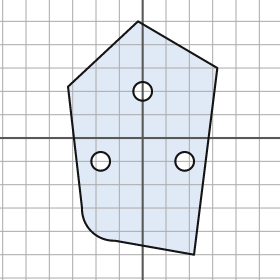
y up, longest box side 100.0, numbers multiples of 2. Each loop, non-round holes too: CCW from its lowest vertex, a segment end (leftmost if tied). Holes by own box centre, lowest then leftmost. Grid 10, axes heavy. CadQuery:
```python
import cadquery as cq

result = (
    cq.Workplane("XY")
    .moveTo(22.0, -50.0)
    .lineTo(32.0, 30.0)
    .lineTo(-2.0, 50.0)
    .lineTo(-32.0, 22.0)
    .lineTo(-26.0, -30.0)
    .threePointArc((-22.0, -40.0), (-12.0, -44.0))
    .close()
    .moveTo(-18.0, -10.0)
    .circle(4.0)
    .moveTo(18.0, -10.0)
    .circle(4.0)
    .moveTo(0.0, 20.0)
    .circle(4.0)
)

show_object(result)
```